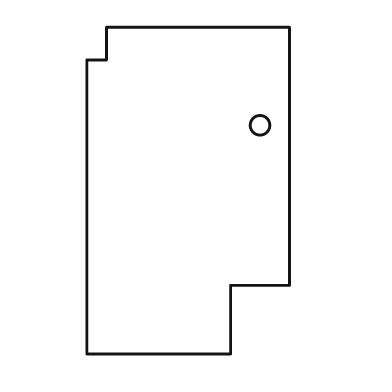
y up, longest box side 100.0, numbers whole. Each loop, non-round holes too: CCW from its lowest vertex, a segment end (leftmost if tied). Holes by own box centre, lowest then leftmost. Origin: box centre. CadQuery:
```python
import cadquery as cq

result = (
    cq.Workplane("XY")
    .moveTo(-31.0, -50.0)
    .lineTo(13.0, -50.0)
    .lineTo(13.0, -29.0)
    .lineTo(31.0, -29.0)
    .lineTo(31.0, 50.0)
    .lineTo(-25.0, 50.0)
    .lineTo(-25.0, 40.0)
    .lineTo(-31.0, 40.0)
    .close()
    .moveTo(22.0, 20.0)
    .circle(3.0)
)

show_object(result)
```